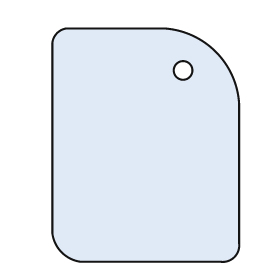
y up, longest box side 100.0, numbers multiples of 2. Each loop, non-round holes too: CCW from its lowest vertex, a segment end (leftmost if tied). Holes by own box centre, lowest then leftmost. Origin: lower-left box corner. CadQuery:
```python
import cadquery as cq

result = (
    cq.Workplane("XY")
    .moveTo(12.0, 0.0)
    .lineTo(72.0, 0.0)
    .threePointArc((78.0, 2.0), (80.0, 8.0))
    .lineTo(80.0, 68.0)
    .threePointArc((70.0, 90.0), (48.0, 100.0))
    .lineTo(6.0, 100.0)
    .threePointArc((2.0, 98.0), (0.0, 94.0))
    .lineTo(0.0, 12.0)
    .threePointArc((4.0, 4.0), (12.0, 0.0))
    .close()
    .moveTo(56.0, 82.0)
    .circle(4.0)
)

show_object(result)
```